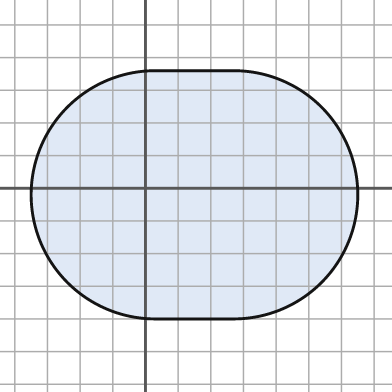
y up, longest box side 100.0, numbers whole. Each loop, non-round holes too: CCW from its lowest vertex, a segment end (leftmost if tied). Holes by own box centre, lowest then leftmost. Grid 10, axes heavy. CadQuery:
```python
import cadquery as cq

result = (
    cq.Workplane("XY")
    .moveTo(3.0, -40.0)
    .lineTo(27.0, -40.0)
    .threePointArc((65.0, -2.0), (27.0, 36.0))
    .lineTo(3.0, 36.0)
    .threePointArc((-35.0, -2.0), (3.0, -40.0))
    .close()
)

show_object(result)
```